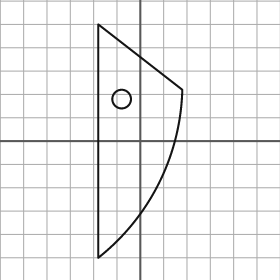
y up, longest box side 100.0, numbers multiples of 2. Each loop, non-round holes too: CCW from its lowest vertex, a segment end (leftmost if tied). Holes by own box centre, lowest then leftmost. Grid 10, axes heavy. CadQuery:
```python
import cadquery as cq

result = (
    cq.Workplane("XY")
    .moveTo(-18.0, -50.0)
    .threePointArc((8.0, -18.0), (18.0, 22.0))
    .lineTo(-18.0, 50.0)
    .close()
    .moveTo(-8.0, 18.0)
    .circle(4.0)
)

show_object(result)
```